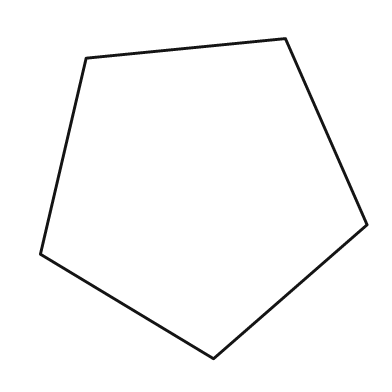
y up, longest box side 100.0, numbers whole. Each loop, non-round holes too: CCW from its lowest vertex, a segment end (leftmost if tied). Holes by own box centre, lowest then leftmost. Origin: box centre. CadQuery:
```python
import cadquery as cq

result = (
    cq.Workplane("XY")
    .moveTo(3.0, -49.0)
    .lineTo(50.0, -8.0)
    .lineTo(25.0, 49.0)
    .lineTo(-36.0, 43.0)
    .lineTo(-50.0, -17.0)
    .close()
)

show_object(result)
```